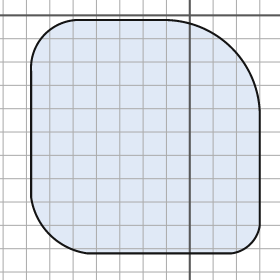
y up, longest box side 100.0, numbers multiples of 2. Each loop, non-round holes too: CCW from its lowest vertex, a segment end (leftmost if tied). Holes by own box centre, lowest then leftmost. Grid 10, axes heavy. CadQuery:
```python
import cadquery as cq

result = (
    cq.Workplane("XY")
    .moveTo(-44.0, -102.0)
    .lineTo(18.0, -102.0)
    .threePointArc((26.0, -98.0), (30.0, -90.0))
    .lineTo(30.0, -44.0)
    .threePointArc((18.0, -14.0), (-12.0, -2.0))
    .lineTo(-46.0, -2.0)
    .threePointArc((-62.0, -8.0), (-68.0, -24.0))
    .lineTo(-68.0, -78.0)
    .threePointArc((-60.0, -94.0), (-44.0, -102.0))
    .close()
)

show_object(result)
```